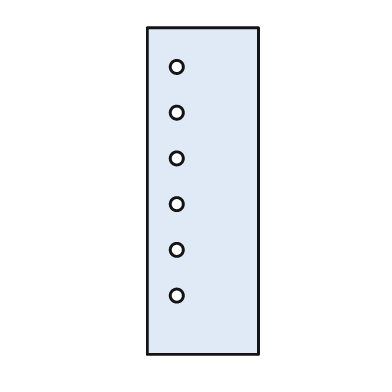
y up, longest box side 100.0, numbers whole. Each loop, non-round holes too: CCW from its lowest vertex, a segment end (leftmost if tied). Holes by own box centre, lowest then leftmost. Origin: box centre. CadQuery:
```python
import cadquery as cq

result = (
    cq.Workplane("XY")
    .moveTo(-17.0, -50.0)
    .lineTo(17.0, -50.0)
    .lineTo(17.0, 50.0)
    .lineTo(-17.0, 50.0)
    .close()
    .moveTo(-8.0, -32.0)
    .circle(2.0)
    .moveTo(-8.0, -18.0)
    .circle(2.0)
    .moveTo(-8.0, -4.0)
    .circle(2.0)
    .moveTo(-8.0, 10.0)
    .circle(2.0)
    .moveTo(-8.0, 24.0)
    .circle(2.0)
    .moveTo(-8.0, 38.0)
    .circle(2.0)
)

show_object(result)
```